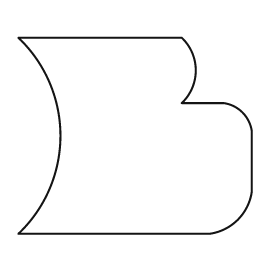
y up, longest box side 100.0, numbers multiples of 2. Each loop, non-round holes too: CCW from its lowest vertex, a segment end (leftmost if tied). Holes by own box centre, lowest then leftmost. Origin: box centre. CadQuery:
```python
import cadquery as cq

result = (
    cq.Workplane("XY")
    .moveTo(-50.0, -42.0)
    .lineTo(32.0, -42.0)
    .threePointArc((44.0, -36.0), (50.0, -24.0))
    .lineTo(50.0, 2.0)
    .threePointArc((46.0, 10.0), (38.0, 14.0))
    .lineTo(20.0, 14.0)
    .threePointArc((26.0, 28.0), (20.0, 42.0))
    .lineTo(-50.0, 42.0)
    .threePointArc((-32.0, 0.0), (-50.0, -42.0))
    .close()
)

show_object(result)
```